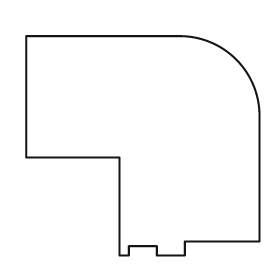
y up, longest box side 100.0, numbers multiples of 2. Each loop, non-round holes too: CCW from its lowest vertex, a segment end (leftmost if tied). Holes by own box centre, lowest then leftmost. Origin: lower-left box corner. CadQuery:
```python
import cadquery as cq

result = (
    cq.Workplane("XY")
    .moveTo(40.0, 0.0)
    .lineTo(44.0, 0.0)
    .lineTo(44.0, 4.0)
    .lineTo(56.0, 4.0)
    .lineTo(56.0, 0.0)
    .lineTo(68.0, 0.0)
    .lineTo(68.0, 6.0)
    .lineTo(100.0, 6.0)
    .lineTo(100.0, 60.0)
    .threePointArc((90.0, 84.0), (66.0, 94.0))
    .lineTo(0.0, 94.0)
    .lineTo(0.0, 42.0)
    .lineTo(40.0, 42.0)
    .close()
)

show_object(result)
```